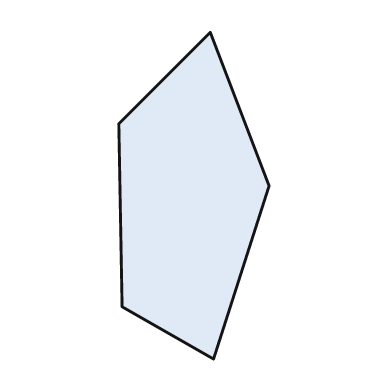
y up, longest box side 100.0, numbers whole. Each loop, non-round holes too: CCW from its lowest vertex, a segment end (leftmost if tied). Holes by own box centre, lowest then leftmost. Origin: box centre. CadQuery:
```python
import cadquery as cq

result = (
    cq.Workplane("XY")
    .moveTo(6.0, -50.0)
    .lineTo(23.0, 3.0)
    .lineTo(5.0, 50.0)
    .lineTo(-23.0, 22.0)
    .lineTo(-22.0, -34.0)
    .close()
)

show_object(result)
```